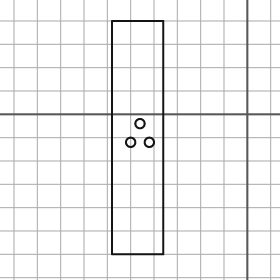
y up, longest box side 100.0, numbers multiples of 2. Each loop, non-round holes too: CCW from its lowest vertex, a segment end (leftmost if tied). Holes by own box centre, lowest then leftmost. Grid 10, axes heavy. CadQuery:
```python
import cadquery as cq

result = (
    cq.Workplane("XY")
    .moveTo(-58.0, -60.0)
    .lineTo(-36.0, -60.0)
    .lineTo(-36.0, 40.0)
    .lineTo(-58.0, 40.0)
    .close()
    .moveTo(-50.0, -12.0)
    .circle(2.0)
    .moveTo(-42.0, -12.0)
    .circle(2.0)
    .moveTo(-46.0, -4.0)
    .circle(2.0)
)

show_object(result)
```